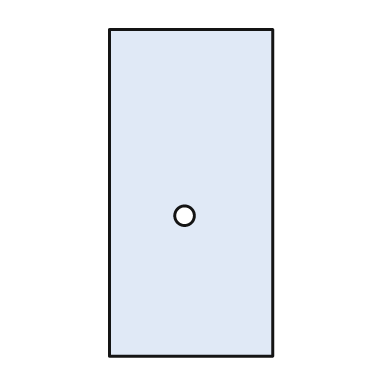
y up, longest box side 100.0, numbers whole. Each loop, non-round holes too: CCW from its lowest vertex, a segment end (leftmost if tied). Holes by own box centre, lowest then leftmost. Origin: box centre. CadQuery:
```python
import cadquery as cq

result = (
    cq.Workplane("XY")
    .moveTo(-25.0, -50.0)
    .lineTo(25.0, -50.0)
    .lineTo(25.0, 50.0)
    .lineTo(-25.0, 50.0)
    .close()
    .moveTo(-2.0, -7.0)
    .circle(3.0)
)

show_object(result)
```